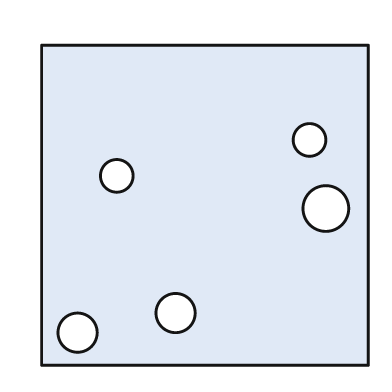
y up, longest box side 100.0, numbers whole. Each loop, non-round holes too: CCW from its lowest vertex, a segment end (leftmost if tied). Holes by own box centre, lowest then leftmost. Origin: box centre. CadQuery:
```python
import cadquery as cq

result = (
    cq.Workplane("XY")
    .moveTo(-50.0, -49.0)
    .lineTo(50.0, -49.0)
    .lineTo(50.0, 49.0)
    .lineTo(-50.0, 49.0)
    .close()
    .moveTo(-39.0, -39.0)
    .circle(6.0)
    .moveTo(-9.0, -33.0)
    .circle(6.0)
    .moveTo(37.0, -1.0)
    .circle(7.0)
    .moveTo(-27.0, 9.0)
    .circle(5.0)
    .moveTo(32.0, 20.0)
    .circle(5.0)
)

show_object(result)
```